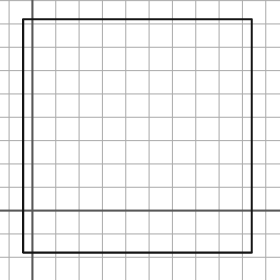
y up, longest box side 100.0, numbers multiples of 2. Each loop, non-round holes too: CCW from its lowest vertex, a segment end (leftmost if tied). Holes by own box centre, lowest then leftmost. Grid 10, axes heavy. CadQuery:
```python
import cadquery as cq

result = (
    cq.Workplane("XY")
    .moveTo(-4.0, -18.0)
    .lineTo(94.0, -18.0)
    .lineTo(94.0, 82.0)
    .lineTo(-4.0, 82.0)
    .close()
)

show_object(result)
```